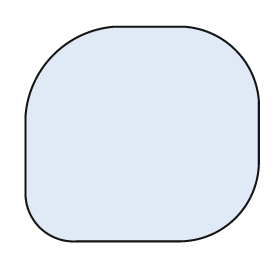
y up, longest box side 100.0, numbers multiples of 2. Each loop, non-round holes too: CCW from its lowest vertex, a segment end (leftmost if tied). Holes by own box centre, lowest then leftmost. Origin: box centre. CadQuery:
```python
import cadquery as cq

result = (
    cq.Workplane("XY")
    .moveTo(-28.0, -46.0)
    .lineTo(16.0, -46.0)
    .threePointArc((40.0, -36.0), (50.0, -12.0))
    .lineTo(50.0, 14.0)
    .threePointArc((40.0, 36.0), (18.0, 46.0))
    .lineTo(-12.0, 46.0)
    .threePointArc((-38.0, 34.0), (-50.0, 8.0))
    .lineTo(-50.0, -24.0)
    .threePointArc((-44.0, -40.0), (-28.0, -46.0))
    .close()
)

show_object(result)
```